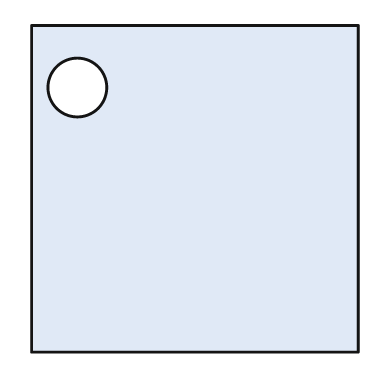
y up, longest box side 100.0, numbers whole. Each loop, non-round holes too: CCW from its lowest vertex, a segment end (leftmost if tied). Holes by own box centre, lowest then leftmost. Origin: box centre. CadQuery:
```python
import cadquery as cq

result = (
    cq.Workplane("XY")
    .moveTo(-50.0, -50.0)
    .lineTo(50.0, -50.0)
    .lineTo(50.0, 50.0)
    .lineTo(-50.0, 50.0)
    .close()
    .moveTo(-36.0, 31.0)
    .circle(9.0)
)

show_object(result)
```